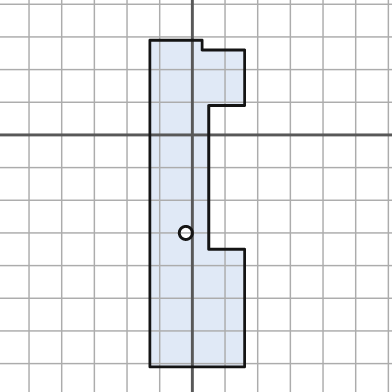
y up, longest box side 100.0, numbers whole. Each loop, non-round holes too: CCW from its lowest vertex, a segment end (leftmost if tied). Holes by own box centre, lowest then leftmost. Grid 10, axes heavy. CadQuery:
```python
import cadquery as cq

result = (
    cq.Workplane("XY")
    .moveTo(-13.0, -71.0)
    .lineTo(16.0, -71.0)
    .lineTo(16.0, -35.0)
    .lineTo(5.0, -35.0)
    .lineTo(5.0, 9.0)
    .lineTo(16.0, 9.0)
    .lineTo(16.0, 26.0)
    .lineTo(3.0, 26.0)
    .lineTo(3.0, 29.0)
    .lineTo(-13.0, 29.0)
    .close()
    .moveTo(-2.0, -30.0)
    .circle(2.0)
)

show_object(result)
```